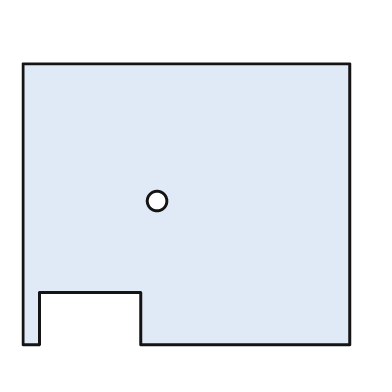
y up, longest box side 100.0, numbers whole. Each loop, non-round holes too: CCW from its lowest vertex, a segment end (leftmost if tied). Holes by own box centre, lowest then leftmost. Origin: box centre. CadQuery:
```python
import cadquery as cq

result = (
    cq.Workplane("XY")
    .moveTo(-50.0, -43.0)
    .lineTo(-45.0, -43.0)
    .lineTo(-45.0, -27.0)
    .lineTo(-14.0, -27.0)
    .lineTo(-14.0, -43.0)
    .lineTo(50.0, -43.0)
    .lineTo(50.0, 43.0)
    .lineTo(-50.0, 43.0)
    .close()
    .moveTo(-9.0, 1.0)
    .circle(3.0)
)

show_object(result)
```